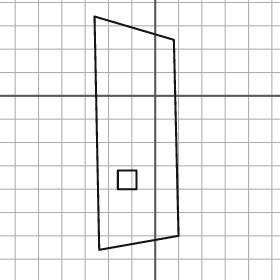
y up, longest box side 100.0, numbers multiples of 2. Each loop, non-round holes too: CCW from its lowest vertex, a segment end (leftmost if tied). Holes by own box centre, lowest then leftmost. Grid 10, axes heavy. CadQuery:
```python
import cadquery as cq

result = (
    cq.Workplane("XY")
    .moveTo(-24.0, -66.0)
    .lineTo(10.0, -60.0)
    .lineTo(8.0, 24.0)
    .lineTo(-26.0, 34.0)
    .close()
    .moveTo(-16.0, -40.0)
    .lineTo(-8.0, -40.0)
    .lineTo(-8.0, -32.0)
    .lineTo(-16.0, -32.0)
    .close()
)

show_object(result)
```